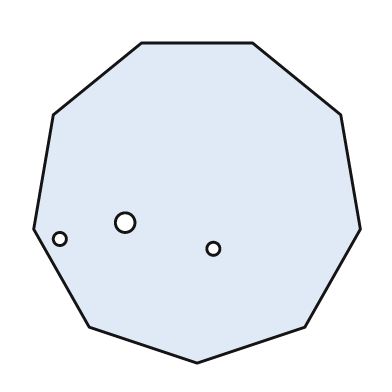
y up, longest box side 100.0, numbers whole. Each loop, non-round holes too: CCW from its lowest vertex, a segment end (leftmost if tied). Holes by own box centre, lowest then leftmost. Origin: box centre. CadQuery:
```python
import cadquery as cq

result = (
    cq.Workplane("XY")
    .moveTo(0.0, -49.0)
    .lineTo(33.0, -38.0)
    .lineTo(50.0, -8.0)
    .lineTo(44.0, 27.0)
    .lineTo(17.0, 49.0)
    .lineTo(-17.0, 49.0)
    .lineTo(-44.0, 27.0)
    .lineTo(-50.0, -8.0)
    .lineTo(-33.0, -38.0)
    .close()
    .moveTo(5.0, -14.0)
    .circle(2.0)
    .moveTo(-42.0, -11.0)
    .circle(2.0)
    .moveTo(-22.0, -6.0)
    .circle(3.0)
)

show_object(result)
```